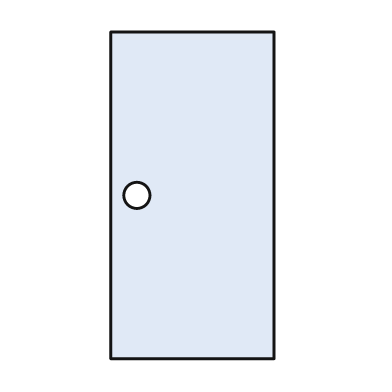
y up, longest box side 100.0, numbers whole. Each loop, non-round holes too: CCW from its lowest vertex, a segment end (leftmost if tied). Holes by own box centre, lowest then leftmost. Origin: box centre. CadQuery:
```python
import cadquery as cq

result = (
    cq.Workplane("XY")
    .moveTo(-25.0, -50.0)
    .lineTo(25.0, -50.0)
    .lineTo(25.0, 50.0)
    .lineTo(-25.0, 50.0)
    .close()
    .moveTo(-17.0, 0.0)
    .circle(4.0)
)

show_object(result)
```